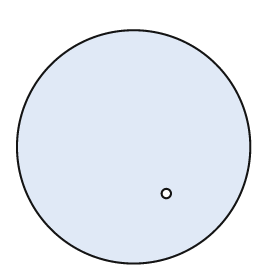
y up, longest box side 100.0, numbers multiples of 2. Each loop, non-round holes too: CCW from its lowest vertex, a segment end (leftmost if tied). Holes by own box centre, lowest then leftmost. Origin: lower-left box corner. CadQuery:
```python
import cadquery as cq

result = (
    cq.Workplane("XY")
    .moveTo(50.0, 50.0)
    .circle(50.0)
    .moveTo(64.0, 30.0)
    .circle(2.0)
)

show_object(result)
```